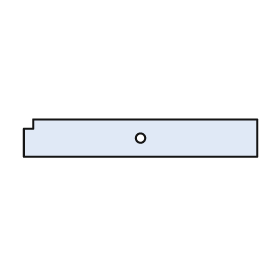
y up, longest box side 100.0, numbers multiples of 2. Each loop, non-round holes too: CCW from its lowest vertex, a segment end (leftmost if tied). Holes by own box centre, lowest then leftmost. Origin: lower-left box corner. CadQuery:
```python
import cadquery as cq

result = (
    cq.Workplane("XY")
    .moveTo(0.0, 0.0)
    .lineTo(100.0, 0.0)
    .lineTo(100.0, 16.0)
    .lineTo(4.0, 16.0)
    .lineTo(4.0, 12.0)
    .lineTo(0.0, 12.0)
    .close()
    .moveTo(50.0, 8.0)
    .circle(2.0)
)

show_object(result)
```